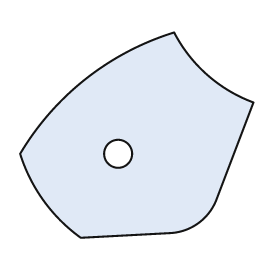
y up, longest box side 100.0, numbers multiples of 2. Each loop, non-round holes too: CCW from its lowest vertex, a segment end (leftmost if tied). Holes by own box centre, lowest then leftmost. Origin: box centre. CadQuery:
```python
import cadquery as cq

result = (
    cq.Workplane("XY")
    .moveTo(-24.0, -44.0)
    .lineTo(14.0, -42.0)
    .threePointArc((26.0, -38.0), (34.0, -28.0))
    .lineTo(50.0, 14.0)
    .threePointArc((30.0, 26.0), (16.0, 44.0))
    .threePointArc((-22.0, 24.0), (-50.0, -8.0))
    .threePointArc((-40.0, -28.0), (-24.0, -44.0))
    .close()
    .moveTo(-8.0, -8.0)
    .circle(6.0)
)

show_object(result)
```